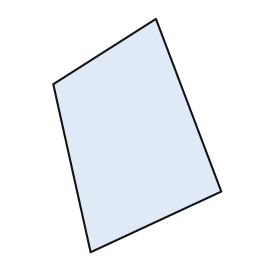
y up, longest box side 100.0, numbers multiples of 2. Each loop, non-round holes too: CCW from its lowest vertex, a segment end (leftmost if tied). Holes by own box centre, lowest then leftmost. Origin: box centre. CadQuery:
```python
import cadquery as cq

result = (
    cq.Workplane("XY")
    .moveTo(-20.0, -50.0)
    .lineTo(36.0, -24.0)
    .lineTo(8.0, 50.0)
    .lineTo(-36.0, 22.0)
    .close()
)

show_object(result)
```